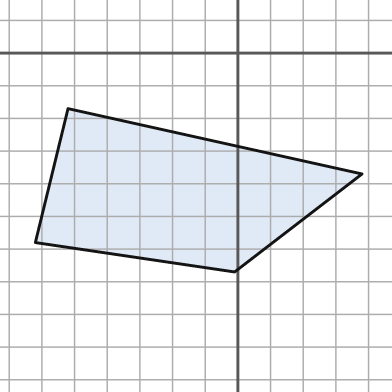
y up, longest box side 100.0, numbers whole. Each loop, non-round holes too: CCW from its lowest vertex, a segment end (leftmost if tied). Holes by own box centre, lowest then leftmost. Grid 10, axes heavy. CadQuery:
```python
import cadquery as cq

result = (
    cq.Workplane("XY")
    .moveTo(-1.0, -67.0)
    .lineTo(38.0, -37.0)
    .lineTo(-52.0, -17.0)
    .lineTo(-62.0, -58.0)
    .close()
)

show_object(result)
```